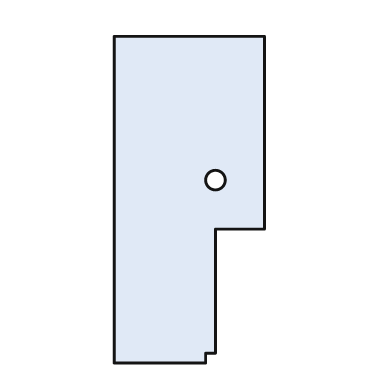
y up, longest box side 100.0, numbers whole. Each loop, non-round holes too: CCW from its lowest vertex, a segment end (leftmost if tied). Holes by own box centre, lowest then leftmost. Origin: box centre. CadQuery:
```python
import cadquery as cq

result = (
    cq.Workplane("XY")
    .moveTo(-23.0, -50.0)
    .lineTo(5.0, -50.0)
    .lineTo(5.0, -47.0)
    .lineTo(8.0, -47.0)
    .lineTo(8.0, -9.0)
    .lineTo(23.0, -9.0)
    .lineTo(23.0, 50.0)
    .lineTo(-23.0, 50.0)
    .close()
    .moveTo(8.0, 6.0)
    .circle(3.0)
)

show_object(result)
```